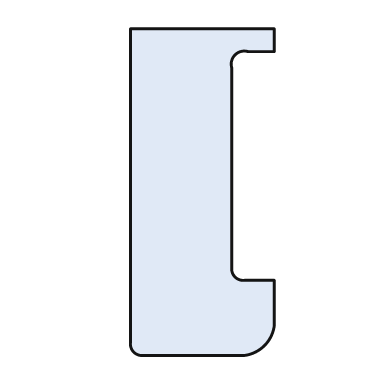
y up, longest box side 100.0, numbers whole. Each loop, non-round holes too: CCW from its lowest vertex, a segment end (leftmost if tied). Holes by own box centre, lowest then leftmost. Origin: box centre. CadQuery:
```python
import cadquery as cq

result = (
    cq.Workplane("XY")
    .moveTo(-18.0, -50.0)
    .lineTo(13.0, -50.0)
    .threePointArc((19.0, -47.0), (22.0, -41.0))
    .lineTo(22.0, -27.0)
    .lineTo(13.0, -27.0)
    .threePointArc((10.0, -26.0), (9.0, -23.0))
    .lineTo(9.0, 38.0)
    .threePointArc((10.0, 42.0), (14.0, 43.0))
    .lineTo(22.0, 43.0)
    .lineTo(22.0, 50.0)
    .lineTo(-22.0, 50.0)
    .lineTo(-22.0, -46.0)
    .threePointArc((-21.0, -49.0), (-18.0, -50.0))
    .close()
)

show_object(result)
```